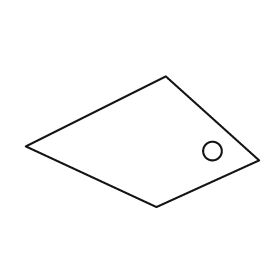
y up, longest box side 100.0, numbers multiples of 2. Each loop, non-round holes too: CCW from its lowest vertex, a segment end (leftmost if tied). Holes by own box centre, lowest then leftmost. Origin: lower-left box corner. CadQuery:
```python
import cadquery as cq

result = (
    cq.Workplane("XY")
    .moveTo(56.0, 0.0)
    .lineTo(100.0, 20.0)
    .lineTo(60.0, 56.0)
    .lineTo(0.0, 26.0)
    .close()
    .moveTo(80.0, 24.0)
    .circle(4.0)
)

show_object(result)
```